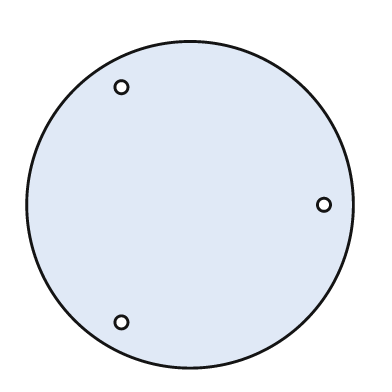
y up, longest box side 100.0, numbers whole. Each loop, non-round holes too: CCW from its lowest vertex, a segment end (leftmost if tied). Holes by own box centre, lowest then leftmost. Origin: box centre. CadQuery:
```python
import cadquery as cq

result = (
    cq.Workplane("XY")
    .moveTo(0.0, 0.0)
    .circle(50.0)
    .moveTo(-21.0, -36.0)
    .circle(2.0)
    .moveTo(41.0, 0.0)
    .circle(2.0)
    .moveTo(-21.0, 36.0)
    .circle(2.0)
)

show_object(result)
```